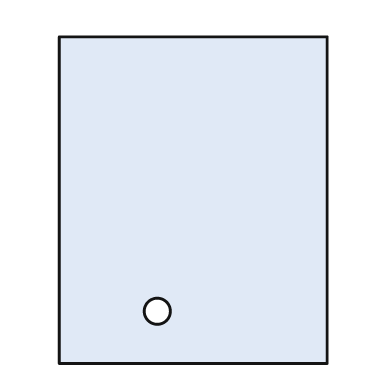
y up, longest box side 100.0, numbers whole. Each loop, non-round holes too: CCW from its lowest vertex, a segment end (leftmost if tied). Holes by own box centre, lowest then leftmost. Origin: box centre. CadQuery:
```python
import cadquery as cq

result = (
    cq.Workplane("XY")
    .moveTo(-41.0, -50.0)
    .lineTo(41.0, -50.0)
    .lineTo(41.0, 50.0)
    .lineTo(-41.0, 50.0)
    .close()
    .moveTo(-11.0, -34.0)
    .circle(4.0)
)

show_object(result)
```